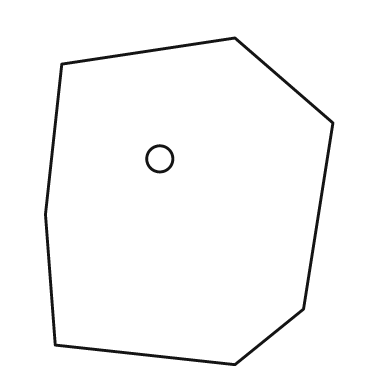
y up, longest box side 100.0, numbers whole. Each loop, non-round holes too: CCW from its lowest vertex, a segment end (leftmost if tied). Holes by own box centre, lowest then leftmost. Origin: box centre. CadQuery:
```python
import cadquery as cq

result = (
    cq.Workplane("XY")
    .moveTo(14.0, -50.0)
    .lineTo(35.0, -33.0)
    .lineTo(44.0, 24.0)
    .lineTo(14.0, 50.0)
    .lineTo(-39.0, 42.0)
    .lineTo(-44.0, -4.0)
    .lineTo(-41.0, -44.0)
    .close()
    .moveTo(-9.0, 13.0)
    .circle(4.0)
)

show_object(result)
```